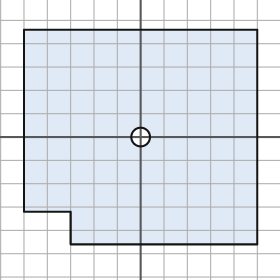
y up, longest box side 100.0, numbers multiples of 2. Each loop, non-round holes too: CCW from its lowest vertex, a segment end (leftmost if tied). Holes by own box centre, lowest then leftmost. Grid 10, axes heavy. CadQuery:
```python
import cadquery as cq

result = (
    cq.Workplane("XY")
    .moveTo(-30.0, -46.0)
    .lineTo(50.0, -46.0)
    .lineTo(50.0, 46.0)
    .lineTo(-50.0, 46.0)
    .lineTo(-50.0, -32.0)
    .lineTo(-30.0, -32.0)
    .close()
    .moveTo(0.0, 0.0)
    .circle(4.0)
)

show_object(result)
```